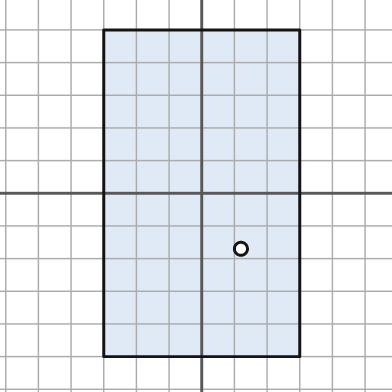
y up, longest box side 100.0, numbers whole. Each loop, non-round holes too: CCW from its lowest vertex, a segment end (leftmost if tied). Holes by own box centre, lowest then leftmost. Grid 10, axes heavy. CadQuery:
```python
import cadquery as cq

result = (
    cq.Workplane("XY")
    .moveTo(-30.0, -50.0)
    .lineTo(30.0, -50.0)
    .lineTo(30.0, 50.0)
    .lineTo(-30.0, 50.0)
    .close()
    .moveTo(12.0, -17.0)
    .circle(2.0)
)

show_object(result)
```